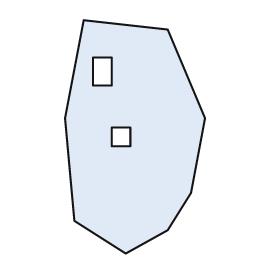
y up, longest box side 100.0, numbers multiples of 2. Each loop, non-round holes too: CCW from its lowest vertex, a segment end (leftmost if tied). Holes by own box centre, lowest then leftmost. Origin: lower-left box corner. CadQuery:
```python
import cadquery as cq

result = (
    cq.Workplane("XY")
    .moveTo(26.0, 0.0)
    .lineTo(44.0, 10.0)
    .lineTo(54.0, 26.0)
    .lineTo(60.0, 58.0)
    .lineTo(44.0, 96.0)
    .lineTo(8.0, 100.0)
    .lineTo(0.0, 58.0)
    .lineTo(4.0, 14.0)
    .close()
    .moveTo(20.0, 46.0)
    .lineTo(28.0, 46.0)
    .lineTo(28.0, 54.0)
    .lineTo(20.0, 54.0)
    .close()
    .moveTo(12.0, 72.0)
    .lineTo(20.0, 72.0)
    .lineTo(20.0, 84.0)
    .lineTo(12.0, 84.0)
    .close()
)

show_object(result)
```